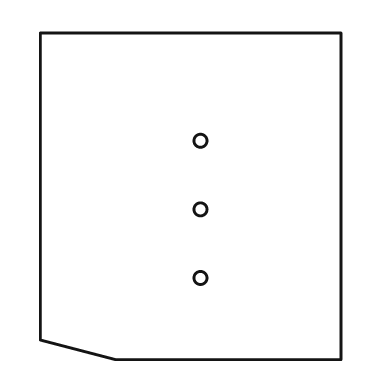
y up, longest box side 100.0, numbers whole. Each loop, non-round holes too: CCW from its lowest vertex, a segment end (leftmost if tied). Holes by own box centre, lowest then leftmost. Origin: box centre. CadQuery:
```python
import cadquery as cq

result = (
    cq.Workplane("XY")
    .moveTo(-23.0, -50.0)
    .lineTo(46.0, -50.0)
    .lineTo(46.0, 50.0)
    .lineTo(-46.0, 50.0)
    .lineTo(-46.0, -44.0)
    .close()
    .moveTo(3.0, -25.0)
    .circle(2.0)
    .moveTo(3.0, -4.0)
    .circle(2.0)
    .moveTo(3.0, 17.0)
    .circle(2.0)
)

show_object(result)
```